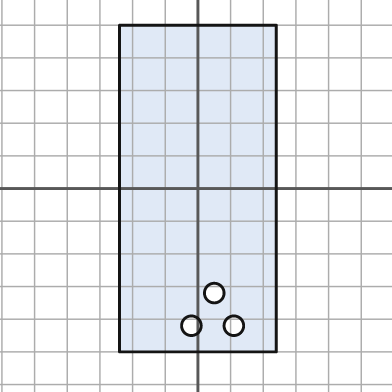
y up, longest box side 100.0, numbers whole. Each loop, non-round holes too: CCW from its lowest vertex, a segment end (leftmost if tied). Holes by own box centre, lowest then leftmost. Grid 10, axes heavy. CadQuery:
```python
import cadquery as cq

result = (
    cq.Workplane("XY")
    .moveTo(-24.0, -50.0)
    .lineTo(24.0, -50.0)
    .lineTo(24.0, 50.0)
    .lineTo(-24.0, 50.0)
    .close()
    .moveTo(-2.0, -42.0)
    .circle(3.0)
    .moveTo(11.0, -42.0)
    .circle(3.0)
    .moveTo(5.0, -32.0)
    .circle(3.0)
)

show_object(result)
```